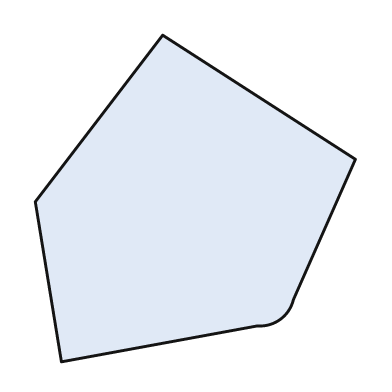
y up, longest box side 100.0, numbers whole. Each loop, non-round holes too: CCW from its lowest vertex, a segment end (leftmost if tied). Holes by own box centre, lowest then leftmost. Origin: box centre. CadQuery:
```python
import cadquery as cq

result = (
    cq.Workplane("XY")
    .moveTo(-41.0, -50.0)
    .lineTo(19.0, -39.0)
    .threePointArc((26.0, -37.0), (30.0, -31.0))
    .lineTo(49.0, 12.0)
    .lineTo(-10.0, 50.0)
    .lineTo(-49.0, -1.0)
    .close()
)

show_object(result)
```